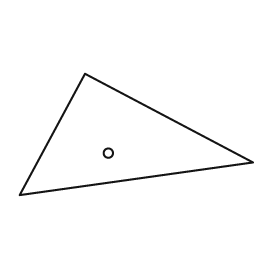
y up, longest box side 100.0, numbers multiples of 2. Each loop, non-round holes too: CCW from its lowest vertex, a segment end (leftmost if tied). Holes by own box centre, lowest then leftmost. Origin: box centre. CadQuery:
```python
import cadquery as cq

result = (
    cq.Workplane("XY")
    .moveTo(-50.0, -26.0)
    .lineTo(50.0, -12.0)
    .lineTo(-22.0, 26.0)
    .close()
    .moveTo(-12.0, -8.0)
    .circle(2.0)
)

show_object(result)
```